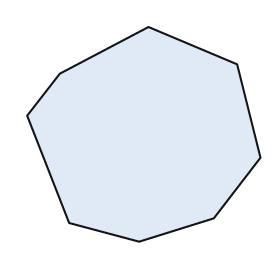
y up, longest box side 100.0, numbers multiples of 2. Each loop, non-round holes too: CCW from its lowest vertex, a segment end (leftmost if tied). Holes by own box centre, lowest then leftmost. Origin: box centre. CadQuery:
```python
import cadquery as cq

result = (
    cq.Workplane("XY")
    .moveTo(-2.0, -46.0)
    .lineTo(30.0, -36.0)
    .lineTo(50.0, -10.0)
    .lineTo(40.0, 30.0)
    .lineTo(2.0, 46.0)
    .lineTo(-36.0, 26.0)
    .lineTo(-50.0, 8.0)
    .lineTo(-32.0, -38.0)
    .close()
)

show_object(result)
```